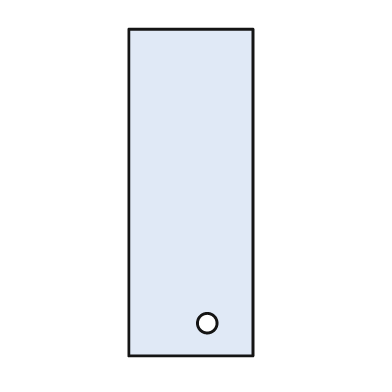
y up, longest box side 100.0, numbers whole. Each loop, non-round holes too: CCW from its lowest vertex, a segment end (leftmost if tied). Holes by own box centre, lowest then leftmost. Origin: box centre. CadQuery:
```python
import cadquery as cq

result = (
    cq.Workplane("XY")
    .moveTo(-19.0, -50.0)
    .lineTo(19.0, -50.0)
    .lineTo(19.0, 50.0)
    .lineTo(-19.0, 50.0)
    .close()
    .moveTo(5.0, -40.0)
    .circle(3.0)
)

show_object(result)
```